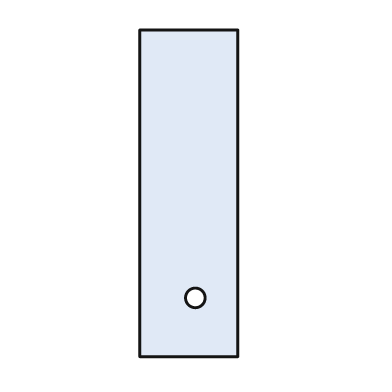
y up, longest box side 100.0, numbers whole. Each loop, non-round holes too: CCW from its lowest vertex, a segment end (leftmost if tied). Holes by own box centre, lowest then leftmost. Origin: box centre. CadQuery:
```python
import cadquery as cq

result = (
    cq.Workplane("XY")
    .moveTo(-15.0, -50.0)
    .lineTo(15.0, -50.0)
    .lineTo(15.0, 50.0)
    .lineTo(-15.0, 50.0)
    .close()
    .moveTo(2.0, -32.0)
    .circle(3.0)
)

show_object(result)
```